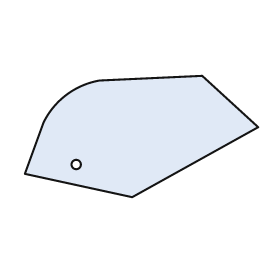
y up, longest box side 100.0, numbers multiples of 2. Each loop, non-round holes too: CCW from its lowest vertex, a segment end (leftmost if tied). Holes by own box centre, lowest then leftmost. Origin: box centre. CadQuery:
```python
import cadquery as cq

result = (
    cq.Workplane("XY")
    .moveTo(-4.0, -26.0)
    .lineTo(50.0, 4.0)
    .lineTo(26.0, 26.0)
    .lineTo(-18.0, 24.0)
    .threePointArc((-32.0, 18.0), (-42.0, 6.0))
    .lineTo(-50.0, -16.0)
    .close()
    .moveTo(-28.0, -12.0)
    .circle(2.0)
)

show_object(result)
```